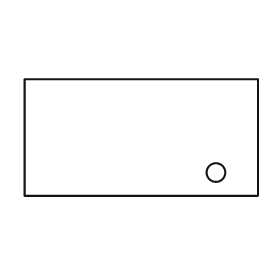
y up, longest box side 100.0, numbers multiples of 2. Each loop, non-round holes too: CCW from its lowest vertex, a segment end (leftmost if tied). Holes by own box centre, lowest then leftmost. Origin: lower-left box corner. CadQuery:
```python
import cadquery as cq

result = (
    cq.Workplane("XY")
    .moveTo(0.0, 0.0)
    .lineTo(100.0, 0.0)
    .lineTo(100.0, 50.0)
    .lineTo(0.0, 50.0)
    .close()
    .moveTo(82.0, 10.0)
    .circle(4.0)
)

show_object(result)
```